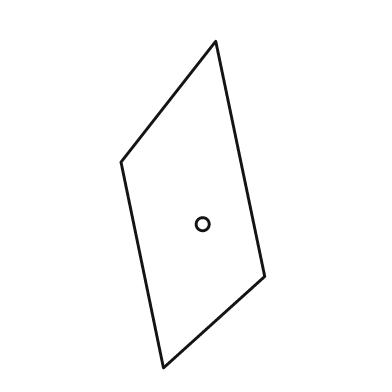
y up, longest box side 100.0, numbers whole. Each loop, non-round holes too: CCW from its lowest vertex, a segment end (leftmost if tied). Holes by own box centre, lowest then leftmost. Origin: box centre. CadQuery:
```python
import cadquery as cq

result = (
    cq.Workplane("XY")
    .moveTo(-9.0, -50.0)
    .lineTo(22.0, -22.0)
    .lineTo(7.0, 50.0)
    .lineTo(-22.0, 13.0)
    .close()
    .moveTo(3.0, -6.0)
    .circle(2.0)
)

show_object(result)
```